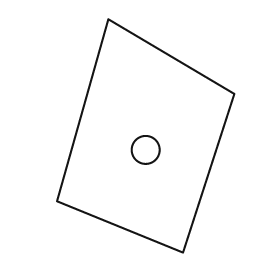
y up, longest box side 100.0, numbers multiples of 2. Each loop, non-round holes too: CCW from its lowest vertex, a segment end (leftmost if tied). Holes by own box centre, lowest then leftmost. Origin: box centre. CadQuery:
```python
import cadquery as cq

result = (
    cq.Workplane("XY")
    .moveTo(16.0, -50.0)
    .lineTo(38.0, 18.0)
    .lineTo(-16.0, 50.0)
    .lineTo(-38.0, -28.0)
    .close()
    .moveTo(0.0, -6.0)
    .circle(6.0)
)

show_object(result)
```